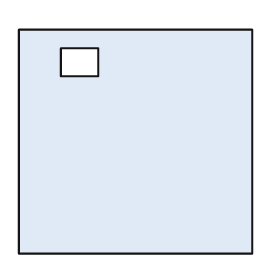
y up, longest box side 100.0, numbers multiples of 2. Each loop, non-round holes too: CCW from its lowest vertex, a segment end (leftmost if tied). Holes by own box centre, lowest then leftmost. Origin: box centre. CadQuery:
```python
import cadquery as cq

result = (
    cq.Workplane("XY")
    .moveTo(-50.0, -48.0)
    .lineTo(50.0, -48.0)
    .lineTo(50.0, 48.0)
    .lineTo(-50.0, 48.0)
    .close()
    .moveTo(-32.0, 28.0)
    .lineTo(-16.0, 28.0)
    .lineTo(-16.0, 40.0)
    .lineTo(-32.0, 40.0)
    .close()
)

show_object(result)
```